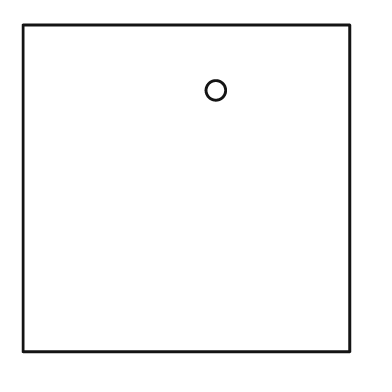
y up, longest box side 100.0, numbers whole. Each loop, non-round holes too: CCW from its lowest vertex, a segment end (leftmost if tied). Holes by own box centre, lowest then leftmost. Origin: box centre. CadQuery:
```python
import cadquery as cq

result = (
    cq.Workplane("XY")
    .moveTo(-50.0, -50.0)
    .lineTo(50.0, -50.0)
    .lineTo(50.0, 50.0)
    .lineTo(-50.0, 50.0)
    .close()
    .moveTo(9.0, 30.0)
    .circle(3.0)
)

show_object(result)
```